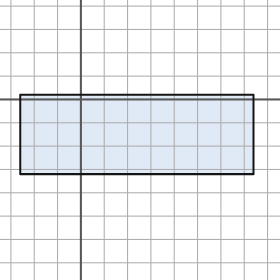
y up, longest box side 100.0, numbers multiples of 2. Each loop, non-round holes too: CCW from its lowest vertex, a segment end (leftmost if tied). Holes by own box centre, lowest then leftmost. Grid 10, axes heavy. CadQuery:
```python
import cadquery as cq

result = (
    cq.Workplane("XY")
    .moveTo(-26.0, -32.0)
    .lineTo(74.0, -32.0)
    .lineTo(74.0, 2.0)
    .lineTo(-26.0, 2.0)
    .close()
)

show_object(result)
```